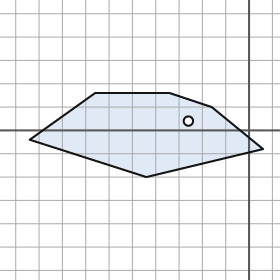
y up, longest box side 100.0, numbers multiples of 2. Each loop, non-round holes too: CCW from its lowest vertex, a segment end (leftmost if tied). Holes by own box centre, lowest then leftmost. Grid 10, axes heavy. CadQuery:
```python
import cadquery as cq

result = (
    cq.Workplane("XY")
    .moveTo(-44.0, -20.0)
    .lineTo(6.0, -8.0)
    .lineTo(-16.0, 10.0)
    .lineTo(-34.0, 16.0)
    .lineTo(-66.0, 16.0)
    .lineTo(-94.0, -4.0)
    .close()
    .moveTo(-26.0, 4.0)
    .circle(2.0)
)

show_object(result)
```